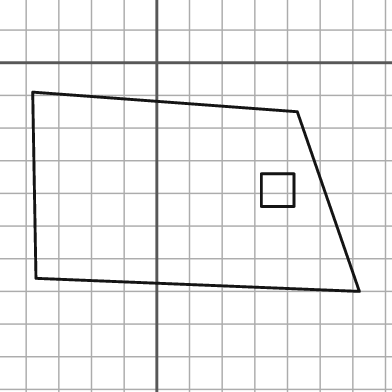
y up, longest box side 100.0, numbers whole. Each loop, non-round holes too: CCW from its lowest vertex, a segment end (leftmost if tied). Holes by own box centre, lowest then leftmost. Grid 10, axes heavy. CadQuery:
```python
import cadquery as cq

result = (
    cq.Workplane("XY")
    .moveTo(62.0, -70.0)
    .lineTo(43.0, -15.0)
    .lineTo(-38.0, -9.0)
    .lineTo(-37.0, -66.0)
    .close()
    .moveTo(32.0, -44.0)
    .lineTo(42.0, -44.0)
    .lineTo(42.0, -34.0)
    .lineTo(32.0, -34.0)
    .close()
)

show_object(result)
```